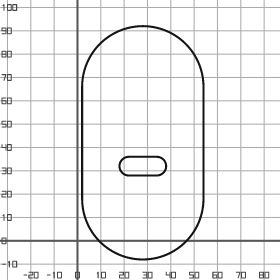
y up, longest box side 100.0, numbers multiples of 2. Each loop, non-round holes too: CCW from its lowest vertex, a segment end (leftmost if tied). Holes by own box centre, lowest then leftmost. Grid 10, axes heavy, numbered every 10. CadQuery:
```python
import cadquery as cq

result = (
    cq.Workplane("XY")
    .moveTo(2.0, 18.0)
    .threePointArc((28.0, -8.0), (54.0, 18.0))
    .lineTo(54.0, 66.0)
    .threePointArc((28.0, 92.0), (2.0, 66.0))
    .close()
    .moveTo(22.0, 28.0)
    .lineTo(34.0, 28.0)
    .threePointArc((38.0, 32.0), (34.0, 36.0))
    .lineTo(22.0, 36.0)
    .threePointArc((18.0, 32.0), (22.0, 28.0))
    .close()
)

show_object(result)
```